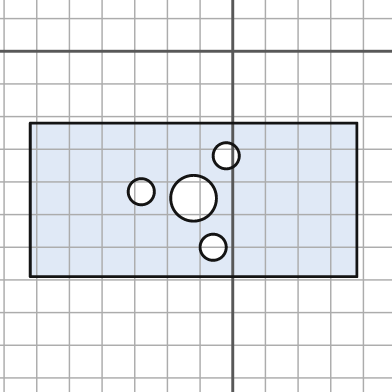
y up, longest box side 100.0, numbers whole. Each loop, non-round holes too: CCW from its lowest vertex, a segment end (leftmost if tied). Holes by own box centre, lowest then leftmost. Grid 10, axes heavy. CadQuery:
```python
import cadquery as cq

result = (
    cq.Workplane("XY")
    .moveTo(-62.0, -69.0)
    .lineTo(38.0, -69.0)
    .lineTo(38.0, -22.0)
    .lineTo(-62.0, -22.0)
    .close()
    .moveTo(-6.0, -60.0)
    .circle(4.0)
    .moveTo(-12.0, -45.0)
    .circle(7.0)
    .moveTo(-28.0, -43.0)
    .circle(4.0)
    .moveTo(-2.0, -32.0)
    .circle(4.0)
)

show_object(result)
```